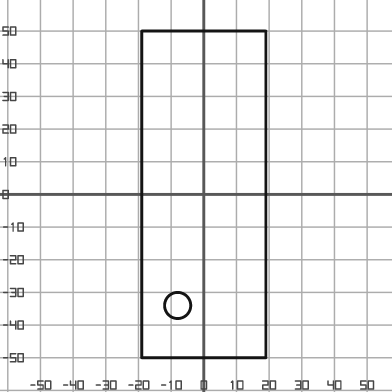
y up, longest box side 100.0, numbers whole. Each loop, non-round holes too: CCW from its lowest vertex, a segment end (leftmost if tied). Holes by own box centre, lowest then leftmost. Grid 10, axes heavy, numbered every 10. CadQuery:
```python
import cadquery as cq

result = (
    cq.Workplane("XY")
    .moveTo(-19.0, -50.0)
    .lineTo(19.0, -50.0)
    .lineTo(19.0, 50.0)
    .lineTo(-19.0, 50.0)
    .close()
    .moveTo(-8.0, -34.0)
    .circle(4.0)
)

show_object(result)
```